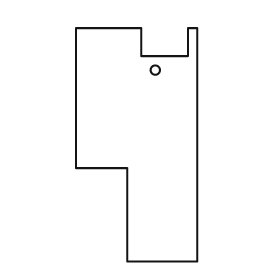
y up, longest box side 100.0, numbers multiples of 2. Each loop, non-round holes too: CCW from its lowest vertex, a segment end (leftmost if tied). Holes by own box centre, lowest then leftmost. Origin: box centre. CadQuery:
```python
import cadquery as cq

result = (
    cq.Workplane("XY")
    .moveTo(-4.0, -50.0)
    .lineTo(26.0, -50.0)
    .lineTo(26.0, 50.0)
    .lineTo(22.0, 50.0)
    .lineTo(22.0, 38.0)
    .lineTo(2.0, 38.0)
    .lineTo(2.0, 50.0)
    .lineTo(-26.0, 50.0)
    .lineTo(-26.0, -10.0)
    .lineTo(-4.0, -10.0)
    .close()
    .moveTo(8.0, 32.0)
    .circle(2.0)
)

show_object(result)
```